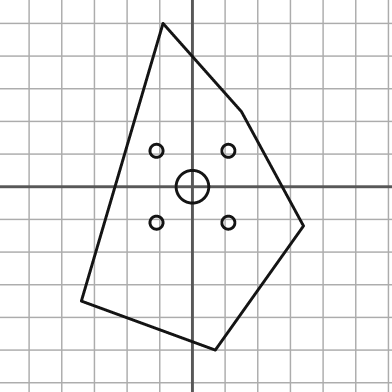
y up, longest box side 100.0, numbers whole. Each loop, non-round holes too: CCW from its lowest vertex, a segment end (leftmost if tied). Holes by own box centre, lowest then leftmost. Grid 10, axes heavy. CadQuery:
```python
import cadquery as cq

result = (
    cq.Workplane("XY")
    .moveTo(7.0, -50.0)
    .lineTo(34.0, -12.0)
    .lineTo(15.0, 23.0)
    .lineTo(-9.0, 50.0)
    .lineTo(-34.0, -35.0)
    .close()
    .moveTo(-11.0, -11.0)
    .circle(2.0)
    .moveTo(11.0, -11.0)
    .circle(2.0)
    .moveTo(0.0, 0.0)
    .circle(5.0)
    .moveTo(-11.0, 11.0)
    .circle(2.0)
    .moveTo(11.0, 11.0)
    .circle(2.0)
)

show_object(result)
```